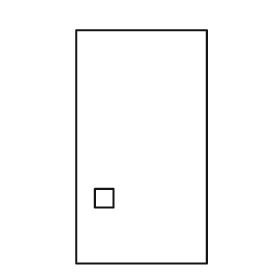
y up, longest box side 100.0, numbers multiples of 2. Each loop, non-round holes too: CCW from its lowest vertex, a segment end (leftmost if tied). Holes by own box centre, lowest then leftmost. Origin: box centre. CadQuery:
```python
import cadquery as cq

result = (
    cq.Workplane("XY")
    .moveTo(-28.0, -50.0)
    .lineTo(28.0, -50.0)
    .lineTo(28.0, 50.0)
    .lineTo(-28.0, 50.0)
    .close()
    .moveTo(-20.0, -26.0)
    .lineTo(-12.0, -26.0)
    .lineTo(-12.0, -18.0)
    .lineTo(-20.0, -18.0)
    .close()
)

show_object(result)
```